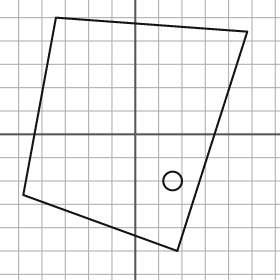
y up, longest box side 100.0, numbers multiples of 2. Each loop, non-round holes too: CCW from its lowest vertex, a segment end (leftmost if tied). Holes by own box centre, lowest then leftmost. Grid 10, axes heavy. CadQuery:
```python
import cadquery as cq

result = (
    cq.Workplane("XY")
    .moveTo(18.0, -50.0)
    .lineTo(48.0, 44.0)
    .lineTo(-34.0, 50.0)
    .lineTo(-48.0, -26.0)
    .close()
    .moveTo(16.0, -20.0)
    .circle(4.0)
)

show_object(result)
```